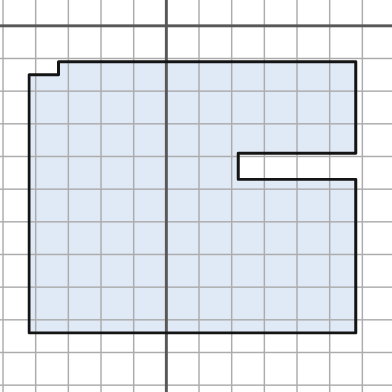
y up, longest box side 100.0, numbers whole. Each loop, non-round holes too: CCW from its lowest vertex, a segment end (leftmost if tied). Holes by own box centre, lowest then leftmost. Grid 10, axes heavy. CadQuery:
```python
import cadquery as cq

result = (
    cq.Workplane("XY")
    .moveTo(-42.0, -94.0)
    .lineTo(58.0, -94.0)
    .lineTo(58.0, -47.0)
    .lineTo(22.0, -47.0)
    .lineTo(22.0, -39.0)
    .lineTo(58.0, -39.0)
    .lineTo(58.0, -11.0)
    .lineTo(-33.0, -11.0)
    .lineTo(-33.0, -15.0)
    .lineTo(-42.0, -15.0)
    .close()
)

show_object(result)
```